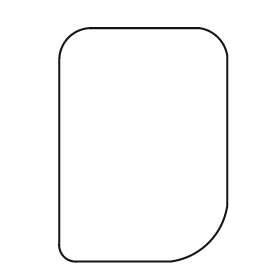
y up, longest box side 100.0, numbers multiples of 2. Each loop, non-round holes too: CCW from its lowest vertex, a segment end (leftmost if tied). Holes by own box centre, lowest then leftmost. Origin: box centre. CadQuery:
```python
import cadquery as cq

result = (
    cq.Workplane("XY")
    .moveTo(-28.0, -50.0)
    .lineTo(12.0, -50.0)
    .threePointArc((28.0, -42.0), (36.0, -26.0))
    .lineTo(36.0, 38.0)
    .threePointArc((32.0, 46.0), (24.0, 50.0))
    .lineTo(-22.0, 50.0)
    .threePointArc((-32.0, 46.0), (-36.0, 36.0))
    .lineTo(-36.0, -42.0)
    .threePointArc((-34.0, -48.0), (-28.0, -50.0))
    .close()
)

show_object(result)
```